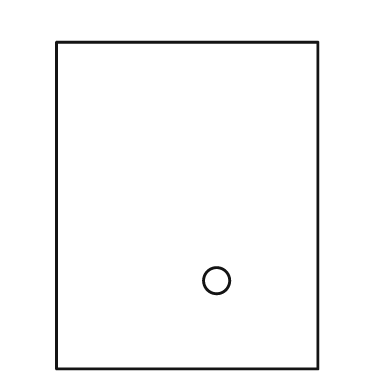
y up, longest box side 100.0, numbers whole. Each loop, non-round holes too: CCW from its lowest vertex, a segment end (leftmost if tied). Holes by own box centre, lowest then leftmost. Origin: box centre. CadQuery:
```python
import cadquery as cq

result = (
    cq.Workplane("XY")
    .moveTo(-40.0, -50.0)
    .lineTo(40.0, -50.0)
    .lineTo(40.0, 50.0)
    .lineTo(-40.0, 50.0)
    .close()
    .moveTo(9.0, -23.0)
    .circle(4.0)
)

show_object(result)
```